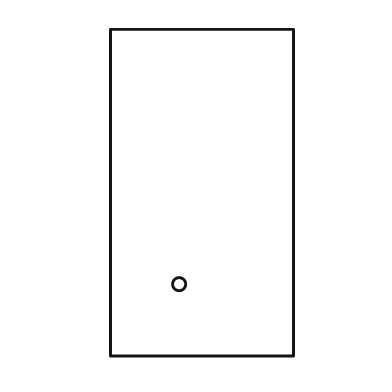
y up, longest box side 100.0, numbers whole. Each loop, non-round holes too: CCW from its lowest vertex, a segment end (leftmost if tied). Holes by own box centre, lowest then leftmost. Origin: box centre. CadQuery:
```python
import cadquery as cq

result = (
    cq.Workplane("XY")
    .moveTo(-28.0, -50.0)
    .lineTo(28.0, -50.0)
    .lineTo(28.0, 50.0)
    .lineTo(-28.0, 50.0)
    .close()
    .moveTo(-7.0, -28.0)
    .circle(2.0)
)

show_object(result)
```